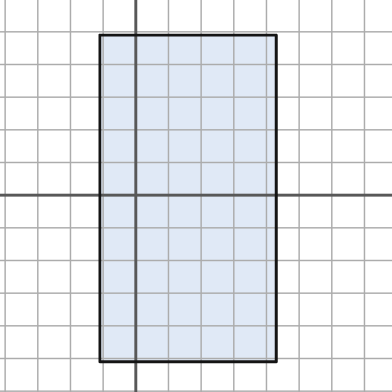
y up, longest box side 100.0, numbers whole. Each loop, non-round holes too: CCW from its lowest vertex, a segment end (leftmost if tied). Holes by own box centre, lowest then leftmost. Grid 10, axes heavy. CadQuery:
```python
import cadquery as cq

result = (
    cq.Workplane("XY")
    .moveTo(-11.0, -51.0)
    .lineTo(43.0, -51.0)
    .lineTo(43.0, 49.0)
    .lineTo(-11.0, 49.0)
    .close()
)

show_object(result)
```